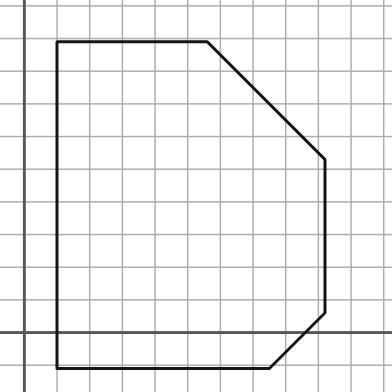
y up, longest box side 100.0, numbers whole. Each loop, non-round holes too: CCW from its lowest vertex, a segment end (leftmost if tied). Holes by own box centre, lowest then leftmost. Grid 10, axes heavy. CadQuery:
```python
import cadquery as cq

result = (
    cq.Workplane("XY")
    .moveTo(10.0, -11.0)
    .lineTo(75.0, -11.0)
    .lineTo(92.0, 6.0)
    .lineTo(92.0, 53.0)
    .lineTo(56.0, 89.0)
    .lineTo(10.0, 89.0)
    .close()
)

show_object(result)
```